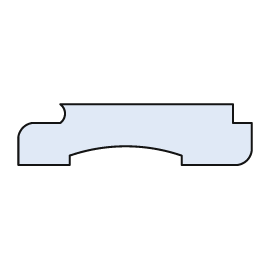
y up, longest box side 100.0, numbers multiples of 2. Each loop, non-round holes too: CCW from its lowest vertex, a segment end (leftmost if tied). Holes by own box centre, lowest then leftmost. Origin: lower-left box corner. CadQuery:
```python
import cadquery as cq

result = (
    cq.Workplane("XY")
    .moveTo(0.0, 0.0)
    .lineTo(22.0, 0.0)
    .lineTo(22.0, 4.0)
    .threePointArc((46.0, 8.0), (70.0, 4.0))
    .lineTo(70.0, 0.0)
    .lineTo(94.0, 0.0)
    .threePointArc((98.0, 2.0), (100.0, 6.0))
    .lineTo(100.0, 18.0)
    .lineTo(92.0, 18.0)
    .lineTo(92.0, 26.0)
    .lineTo(18.0, 26.0)
    .threePointArc((20.0, 22.0), (18.0, 18.0))
    .lineTo(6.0, 18.0)
    .threePointArc((2.0, 16.0), (0.0, 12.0))
    .close()
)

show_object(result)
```